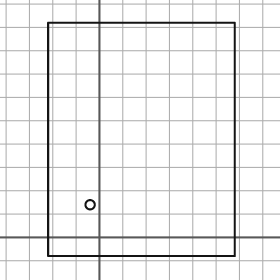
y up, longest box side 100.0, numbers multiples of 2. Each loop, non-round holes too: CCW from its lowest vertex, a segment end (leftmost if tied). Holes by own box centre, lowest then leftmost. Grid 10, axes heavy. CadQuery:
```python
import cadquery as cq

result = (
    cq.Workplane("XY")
    .moveTo(-22.0, -8.0)
    .lineTo(58.0, -8.0)
    .lineTo(58.0, 92.0)
    .lineTo(-22.0, 92.0)
    .close()
    .moveTo(-4.0, 14.0)
    .circle(2.0)
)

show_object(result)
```